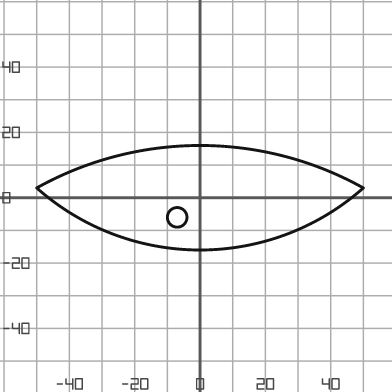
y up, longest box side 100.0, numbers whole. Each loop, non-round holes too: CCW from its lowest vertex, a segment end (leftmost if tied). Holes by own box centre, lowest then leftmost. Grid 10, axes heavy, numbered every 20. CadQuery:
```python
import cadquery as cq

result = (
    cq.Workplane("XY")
    .moveTo(-50.0, 3.0)
    .threePointArc((0.0, -16.0), (50.0, 3.0))
    .threePointArc((0.0, 16.0), (-50.0, 3.0))
    .close()
    .moveTo(-7.0, -6.0)
    .circle(3.0)
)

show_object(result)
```